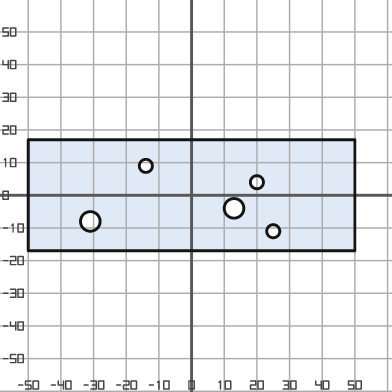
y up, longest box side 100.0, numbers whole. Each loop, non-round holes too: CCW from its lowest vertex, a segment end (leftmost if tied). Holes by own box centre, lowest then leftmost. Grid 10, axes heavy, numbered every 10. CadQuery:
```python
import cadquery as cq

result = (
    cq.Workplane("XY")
    .moveTo(-50.0, -17.0)
    .lineTo(50.0, -17.0)
    .lineTo(50.0, 17.0)
    .lineTo(-50.0, 17.0)
    .close()
    .moveTo(25.0, -11.0)
    .circle(2.0)
    .moveTo(-31.0, -8.0)
    .circle(3.0)
    .moveTo(13.0, -4.0)
    .circle(3.0)
    .moveTo(20.0, 4.0)
    .circle(2.0)
    .moveTo(-14.0, 9.0)
    .circle(2.0)
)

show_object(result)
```